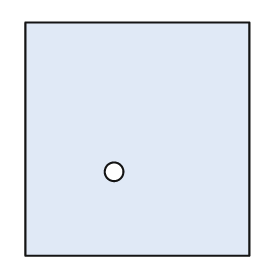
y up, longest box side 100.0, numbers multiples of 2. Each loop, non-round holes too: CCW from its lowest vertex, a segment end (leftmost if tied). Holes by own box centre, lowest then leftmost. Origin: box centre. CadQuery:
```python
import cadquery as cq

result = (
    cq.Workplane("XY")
    .moveTo(-48.0, -50.0)
    .lineTo(48.0, -50.0)
    .lineTo(48.0, 50.0)
    .lineTo(-48.0, 50.0)
    .close()
    .moveTo(-10.0, -14.0)
    .circle(4.0)
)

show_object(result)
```